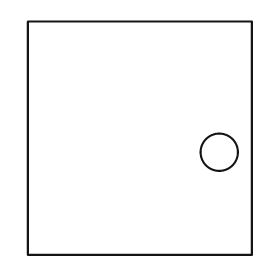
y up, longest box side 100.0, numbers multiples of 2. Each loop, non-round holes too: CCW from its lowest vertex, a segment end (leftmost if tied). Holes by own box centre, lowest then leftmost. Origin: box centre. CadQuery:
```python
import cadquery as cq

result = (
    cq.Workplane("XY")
    .moveTo(-48.0, -50.0)
    .lineTo(48.0, -50.0)
    .lineTo(48.0, 50.0)
    .lineTo(-48.0, 50.0)
    .close()
    .moveTo(34.0, -6.0)
    .circle(8.0)
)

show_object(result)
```